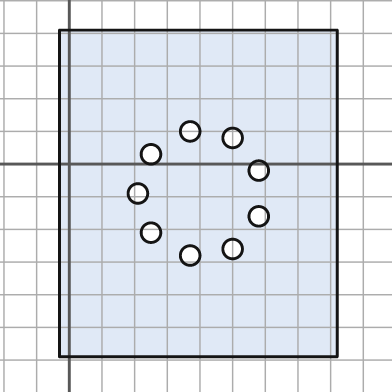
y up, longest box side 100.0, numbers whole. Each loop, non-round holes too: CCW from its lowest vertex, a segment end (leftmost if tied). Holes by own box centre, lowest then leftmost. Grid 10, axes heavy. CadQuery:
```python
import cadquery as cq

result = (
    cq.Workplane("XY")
    .moveTo(-3.0, -59.0)
    .lineTo(82.0, -59.0)
    .lineTo(82.0, 41.0)
    .lineTo(-3.0, 41.0)
    .close()
    .moveTo(37.0, -28.0)
    .circle(3.0)
    .moveTo(50.0, -26.0)
    .circle(3.0)
    .moveTo(25.0, -21.0)
    .circle(3.0)
    .moveTo(58.0, -16.0)
    .circle(3.0)
    .moveTo(21.0, -9.0)
    .circle(3.0)
    .moveTo(58.0, -2.0)
    .circle(3.0)
    .moveTo(25.0, 3.0)
    .circle(3.0)
    .moveTo(50.0, 8.0)
    .circle(3.0)
    .moveTo(37.0, 10.0)
    .circle(3.0)
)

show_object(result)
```